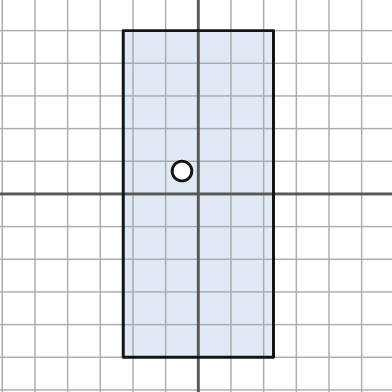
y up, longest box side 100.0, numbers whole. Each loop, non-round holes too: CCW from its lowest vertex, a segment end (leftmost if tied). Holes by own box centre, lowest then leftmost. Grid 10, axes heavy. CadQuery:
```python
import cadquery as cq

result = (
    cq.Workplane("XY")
    .moveTo(-23.0, -50.0)
    .lineTo(23.0, -50.0)
    .lineTo(23.0, 50.0)
    .lineTo(-23.0, 50.0)
    .close()
    .moveTo(-5.0, 7.0)
    .circle(3.0)
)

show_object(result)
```